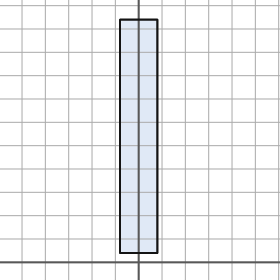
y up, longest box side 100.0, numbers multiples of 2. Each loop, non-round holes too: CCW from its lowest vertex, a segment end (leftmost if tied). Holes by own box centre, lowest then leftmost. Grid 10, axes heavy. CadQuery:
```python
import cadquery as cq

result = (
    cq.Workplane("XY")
    .moveTo(-8.0, 4.0)
    .lineTo(8.0, 4.0)
    .lineTo(8.0, 104.0)
    .lineTo(-8.0, 104.0)
    .close()
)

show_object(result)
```